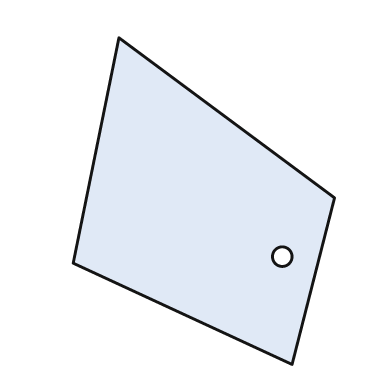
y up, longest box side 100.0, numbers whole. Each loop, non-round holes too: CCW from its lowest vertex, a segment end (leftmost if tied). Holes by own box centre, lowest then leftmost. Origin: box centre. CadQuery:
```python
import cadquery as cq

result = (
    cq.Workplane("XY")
    .moveTo(27.0, -50.0)
    .lineTo(40.0, 1.0)
    .lineTo(-26.0, 50.0)
    .lineTo(-40.0, -19.0)
    .close()
    .moveTo(24.0, -17.0)
    .circle(3.0)
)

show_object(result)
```